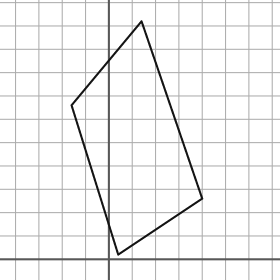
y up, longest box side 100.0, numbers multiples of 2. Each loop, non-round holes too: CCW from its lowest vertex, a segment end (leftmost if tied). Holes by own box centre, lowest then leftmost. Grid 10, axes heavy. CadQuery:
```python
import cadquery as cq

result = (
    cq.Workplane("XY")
    .moveTo(4.0, 2.0)
    .lineTo(40.0, 26.0)
    .lineTo(14.0, 102.0)
    .lineTo(-16.0, 66.0)
    .close()
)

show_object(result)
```